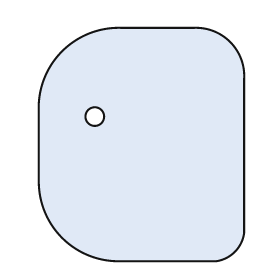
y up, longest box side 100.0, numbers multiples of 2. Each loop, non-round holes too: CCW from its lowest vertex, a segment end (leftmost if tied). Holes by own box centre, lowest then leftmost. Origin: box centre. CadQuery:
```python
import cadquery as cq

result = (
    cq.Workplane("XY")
    .moveTo(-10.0, -50.0)
    .lineTo(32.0, -50.0)
    .threePointArc((40.0, -46.0), (44.0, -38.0))
    .lineTo(44.0, 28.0)
    .threePointArc((38.0, 44.0), (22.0, 50.0))
    .lineTo(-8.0, 50.0)
    .threePointArc((-34.0, 40.0), (-44.0, 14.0))
    .lineTo(-44.0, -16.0)
    .threePointArc((-34.0, -40.0), (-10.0, -50.0))
    .close()
    .moveTo(-20.0, 12.0)
    .circle(4.0)
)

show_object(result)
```